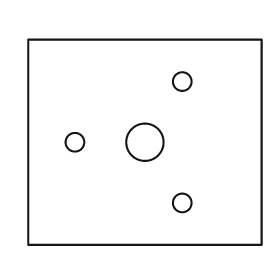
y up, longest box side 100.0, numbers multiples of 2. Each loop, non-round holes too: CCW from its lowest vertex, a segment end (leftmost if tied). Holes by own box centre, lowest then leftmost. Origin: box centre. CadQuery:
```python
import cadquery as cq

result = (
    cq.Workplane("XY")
    .moveTo(-50.0, -44.0)
    .lineTo(50.0, -44.0)
    .lineTo(50.0, 44.0)
    .lineTo(-50.0, 44.0)
    .close()
    .moveTo(16.0, -26.0)
    .circle(4.0)
    .moveTo(-30.0, 0.0)
    .circle(4.0)
    .moveTo(0.0, 0.0)
    .circle(8.0)
    .moveTo(16.0, 26.0)
    .circle(4.0)
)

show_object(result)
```